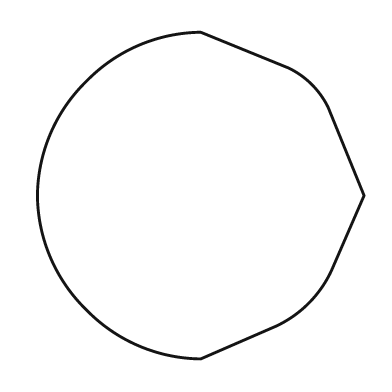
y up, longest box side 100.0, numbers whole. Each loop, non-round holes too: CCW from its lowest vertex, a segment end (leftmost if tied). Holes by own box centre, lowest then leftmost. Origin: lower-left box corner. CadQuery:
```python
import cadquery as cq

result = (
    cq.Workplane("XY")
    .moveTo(50.0, 0.0)
    .lineTo(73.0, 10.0)
    .threePointArc((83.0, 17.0), (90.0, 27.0))
    .lineTo(100.0, 50.0)
    .lineTo(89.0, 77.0)
    .threePointArc((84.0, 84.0), (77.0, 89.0))
    .lineTo(50.0, 100.0)
    .threePointArc((31.0, 96.0), (15.0, 85.0))
    .threePointArc((4.0, 69.0), (0.0, 50.0))
    .threePointArc((4.0, 31.0), (15.0, 15.0))
    .threePointArc((31.0, 4.0), (50.0, 0.0))
    .close()
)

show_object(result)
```